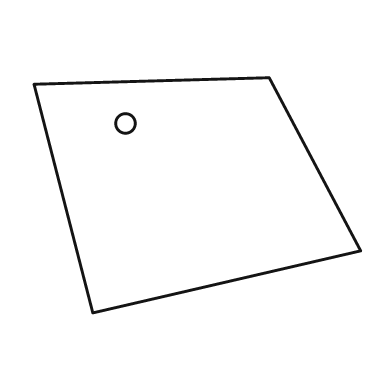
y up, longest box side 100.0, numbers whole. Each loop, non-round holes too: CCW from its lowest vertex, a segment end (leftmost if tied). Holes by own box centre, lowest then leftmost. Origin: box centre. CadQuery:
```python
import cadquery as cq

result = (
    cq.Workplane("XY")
    .moveTo(-32.0, -36.0)
    .lineTo(50.0, -17.0)
    .lineTo(22.0, 36.0)
    .lineTo(-50.0, 34.0)
    .close()
    .moveTo(-22.0, 22.0)
    .circle(3.0)
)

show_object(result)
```